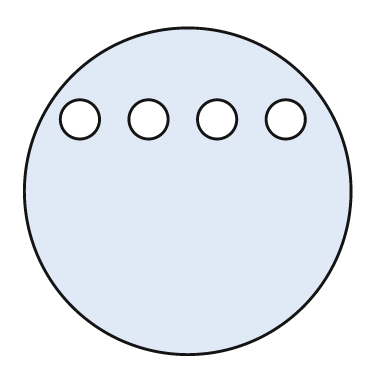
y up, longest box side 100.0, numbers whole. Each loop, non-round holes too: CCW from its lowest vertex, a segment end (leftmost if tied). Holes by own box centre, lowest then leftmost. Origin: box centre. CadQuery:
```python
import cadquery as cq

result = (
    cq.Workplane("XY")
    .moveTo(0.0, 0.0)
    .circle(50.0)
    .moveTo(-33.0, 22.0)
    .circle(6.0)
    .moveTo(-12.0, 22.0)
    .circle(6.0)
    .moveTo(9.0, 22.0)
    .circle(6.0)
    .moveTo(30.0, 22.0)
    .circle(6.0)
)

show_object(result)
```